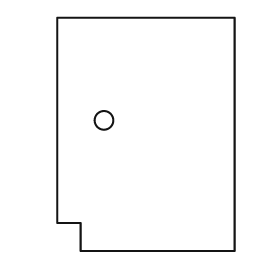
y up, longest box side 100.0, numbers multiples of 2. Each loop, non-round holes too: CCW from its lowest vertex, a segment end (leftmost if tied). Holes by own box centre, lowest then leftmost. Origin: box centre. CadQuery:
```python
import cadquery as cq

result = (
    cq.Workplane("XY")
    .moveTo(-28.0, -50.0)
    .lineTo(38.0, -50.0)
    .lineTo(38.0, 50.0)
    .lineTo(-38.0, 50.0)
    .lineTo(-38.0, -38.0)
    .lineTo(-28.0, -38.0)
    .close()
    .moveTo(-18.0, 6.0)
    .circle(4.0)
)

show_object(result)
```